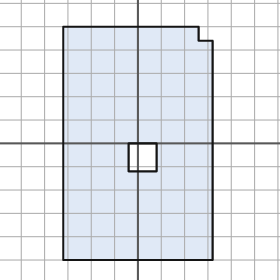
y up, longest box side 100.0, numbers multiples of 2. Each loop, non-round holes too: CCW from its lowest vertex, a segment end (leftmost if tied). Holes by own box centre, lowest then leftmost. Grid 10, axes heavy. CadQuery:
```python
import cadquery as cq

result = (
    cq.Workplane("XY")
    .moveTo(-32.0, -50.0)
    .lineTo(32.0, -50.0)
    .lineTo(32.0, 44.0)
    .lineTo(26.0, 44.0)
    .lineTo(26.0, 50.0)
    .lineTo(-32.0, 50.0)
    .close()
    .moveTo(-4.0, -12.0)
    .lineTo(8.0, -12.0)
    .lineTo(8.0, 0.0)
    .lineTo(-4.0, 0.0)
    .close()
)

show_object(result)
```